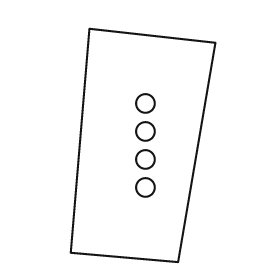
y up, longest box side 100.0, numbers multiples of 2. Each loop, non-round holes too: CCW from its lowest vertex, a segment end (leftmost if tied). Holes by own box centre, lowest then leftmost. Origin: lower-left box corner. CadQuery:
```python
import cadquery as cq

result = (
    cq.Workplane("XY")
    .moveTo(46.0, 0.0)
    .lineTo(62.0, 94.0)
    .lineTo(8.0, 100.0)
    .lineTo(0.0, 4.0)
    .close()
    .moveTo(32.0, 32.0)
    .circle(4.0)
    .moveTo(32.0, 44.0)
    .circle(4.0)
    .moveTo(32.0, 56.0)
    .circle(4.0)
    .moveTo(32.0, 68.0)
    .circle(4.0)
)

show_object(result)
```